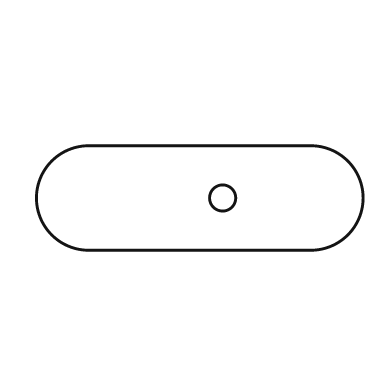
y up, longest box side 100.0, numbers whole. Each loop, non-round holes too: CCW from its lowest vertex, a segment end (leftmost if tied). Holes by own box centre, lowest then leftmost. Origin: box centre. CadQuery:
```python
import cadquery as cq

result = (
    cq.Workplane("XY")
    .moveTo(-34.0, -16.0)
    .lineTo(34.0, -16.0)
    .threePointArc((50.0, 0.0), (34.0, 16.0))
    .lineTo(-34.0, 16.0)
    .threePointArc((-50.0, 0.0), (-34.0, -16.0))
    .close()
    .moveTo(7.0, 0.0)
    .circle(4.0)
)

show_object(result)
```